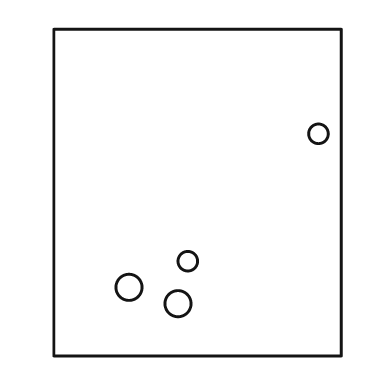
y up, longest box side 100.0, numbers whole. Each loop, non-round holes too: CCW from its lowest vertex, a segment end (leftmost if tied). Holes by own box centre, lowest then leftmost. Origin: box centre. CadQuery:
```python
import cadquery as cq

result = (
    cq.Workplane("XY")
    .moveTo(-44.0, -50.0)
    .lineTo(44.0, -50.0)
    .lineTo(44.0, 50.0)
    .lineTo(-44.0, 50.0)
    .close()
    .moveTo(-6.0, -34.0)
    .circle(4.0)
    .moveTo(-21.0, -29.0)
    .circle(4.0)
    .moveTo(-3.0, -21.0)
    .circle(3.0)
    .moveTo(37.0, 18.0)
    .circle(3.0)
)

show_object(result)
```